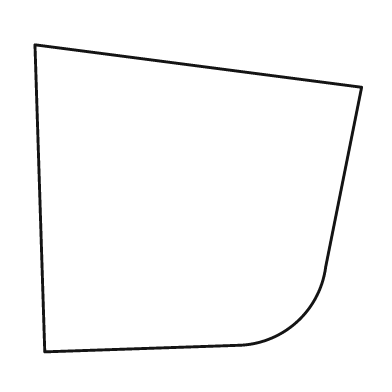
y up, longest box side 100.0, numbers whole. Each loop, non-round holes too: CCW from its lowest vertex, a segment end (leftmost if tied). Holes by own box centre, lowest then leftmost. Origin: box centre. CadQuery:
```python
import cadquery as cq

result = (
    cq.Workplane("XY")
    .moveTo(-47.0, -47.0)
    .lineTo(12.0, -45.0)
    .threePointArc((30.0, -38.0), (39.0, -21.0))
    .lineTo(50.0, 34.0)
    .lineTo(-50.0, 47.0)
    .close()
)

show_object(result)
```